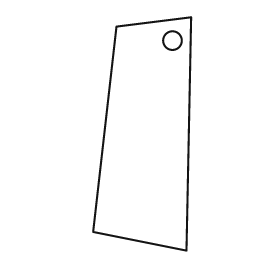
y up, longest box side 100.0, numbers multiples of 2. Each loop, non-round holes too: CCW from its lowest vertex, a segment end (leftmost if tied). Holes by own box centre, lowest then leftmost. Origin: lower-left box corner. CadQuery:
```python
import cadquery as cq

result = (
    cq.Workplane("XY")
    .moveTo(40.0, 0.0)
    .lineTo(42.0, 100.0)
    .lineTo(10.0, 96.0)
    .lineTo(0.0, 8.0)
    .close()
    .moveTo(34.0, 90.0)
    .circle(4.0)
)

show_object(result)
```